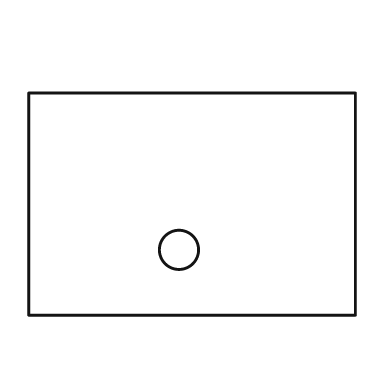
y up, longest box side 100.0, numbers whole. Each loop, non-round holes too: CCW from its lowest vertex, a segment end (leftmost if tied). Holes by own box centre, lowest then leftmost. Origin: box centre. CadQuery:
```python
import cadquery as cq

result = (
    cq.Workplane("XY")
    .moveTo(-50.0, -34.0)
    .lineTo(50.0, -34.0)
    .lineTo(50.0, 34.0)
    .lineTo(-50.0, 34.0)
    .close()
    .moveTo(-4.0, -14.0)
    .circle(6.0)
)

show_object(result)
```